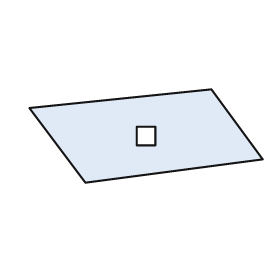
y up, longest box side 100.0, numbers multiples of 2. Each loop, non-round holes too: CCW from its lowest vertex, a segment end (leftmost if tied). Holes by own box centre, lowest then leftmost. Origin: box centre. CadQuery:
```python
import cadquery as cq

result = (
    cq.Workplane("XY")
    .moveTo(-26.0, -20.0)
    .lineTo(50.0, -10.0)
    .lineTo(28.0, 20.0)
    .lineTo(-50.0, 12.0)
    .close()
    .moveTo(-4.0, -4.0)
    .lineTo(4.0, -4.0)
    .lineTo(4.0, 4.0)
    .lineTo(-4.0, 4.0)
    .close()
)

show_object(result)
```